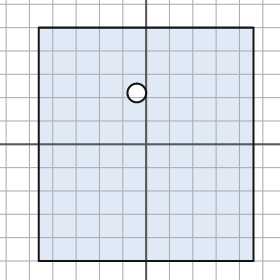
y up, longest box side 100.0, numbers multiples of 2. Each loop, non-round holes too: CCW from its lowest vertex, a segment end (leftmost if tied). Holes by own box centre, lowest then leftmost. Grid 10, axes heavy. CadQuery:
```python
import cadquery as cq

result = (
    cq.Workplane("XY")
    .moveTo(-46.0, -50.0)
    .lineTo(46.0, -50.0)
    .lineTo(46.0, 50.0)
    .lineTo(-46.0, 50.0)
    .close()
    .moveTo(-4.0, 22.0)
    .circle(4.0)
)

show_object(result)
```